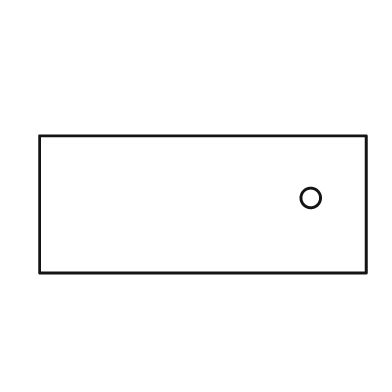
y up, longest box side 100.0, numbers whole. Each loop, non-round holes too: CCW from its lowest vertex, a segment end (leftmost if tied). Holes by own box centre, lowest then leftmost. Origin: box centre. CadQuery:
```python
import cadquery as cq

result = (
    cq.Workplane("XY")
    .moveTo(-50.0, -21.0)
    .lineTo(50.0, -21.0)
    .lineTo(50.0, 21.0)
    .lineTo(-50.0, 21.0)
    .close()
    .moveTo(33.0, 2.0)
    .circle(3.0)
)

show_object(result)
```